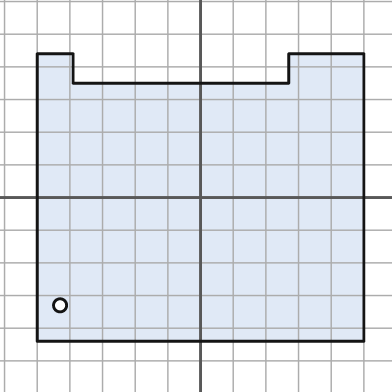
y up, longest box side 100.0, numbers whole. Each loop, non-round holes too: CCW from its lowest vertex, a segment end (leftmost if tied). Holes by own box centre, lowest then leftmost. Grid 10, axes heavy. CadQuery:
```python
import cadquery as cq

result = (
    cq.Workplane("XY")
    .moveTo(-50.0, -44.0)
    .lineTo(50.0, -44.0)
    .lineTo(50.0, 44.0)
    .lineTo(27.0, 44.0)
    .lineTo(27.0, 35.0)
    .lineTo(-39.0, 35.0)
    .lineTo(-39.0, 44.0)
    .lineTo(-50.0, 44.0)
    .close()
    .moveTo(-43.0, -33.0)
    .circle(2.0)
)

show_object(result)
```